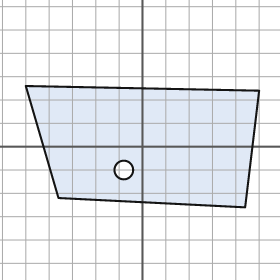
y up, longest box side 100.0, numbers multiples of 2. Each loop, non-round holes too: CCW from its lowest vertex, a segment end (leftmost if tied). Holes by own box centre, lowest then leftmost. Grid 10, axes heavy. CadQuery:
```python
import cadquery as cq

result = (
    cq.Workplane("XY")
    .moveTo(44.0, -26.0)
    .lineTo(50.0, 24.0)
    .lineTo(-50.0, 26.0)
    .lineTo(-36.0, -22.0)
    .close()
    .moveTo(-8.0, -10.0)
    .circle(4.0)
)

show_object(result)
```